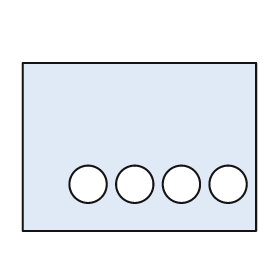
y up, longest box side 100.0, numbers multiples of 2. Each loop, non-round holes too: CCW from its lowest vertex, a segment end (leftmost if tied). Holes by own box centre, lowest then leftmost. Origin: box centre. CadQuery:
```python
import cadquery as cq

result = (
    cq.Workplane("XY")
    .moveTo(-50.0, -36.0)
    .lineTo(50.0, -36.0)
    .lineTo(50.0, 36.0)
    .lineTo(-50.0, 36.0)
    .close()
    .moveTo(-22.0, -16.0)
    .circle(8.0)
    .moveTo(-2.0, -16.0)
    .circle(8.0)
    .moveTo(18.0, -16.0)
    .circle(8.0)
    .moveTo(38.0, -16.0)
    .circle(8.0)
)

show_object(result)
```